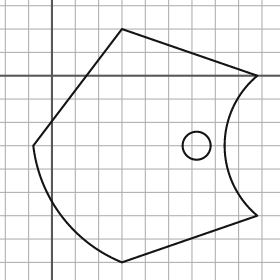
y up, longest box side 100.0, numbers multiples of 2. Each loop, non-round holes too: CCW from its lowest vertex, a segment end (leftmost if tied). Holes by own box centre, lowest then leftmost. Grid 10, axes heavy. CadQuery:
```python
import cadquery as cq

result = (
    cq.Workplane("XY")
    .moveTo(30.0, -80.0)
    .lineTo(88.0, -60.0)
    .threePointArc((74.0, -30.0), (88.0, 0.0))
    .lineTo(30.0, 20.0)
    .lineTo(-8.0, -30.0)
    .threePointArc((4.0, -60.0), (30.0, -80.0))
    .close()
    .moveTo(62.0, -30.0)
    .circle(6.0)
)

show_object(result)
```